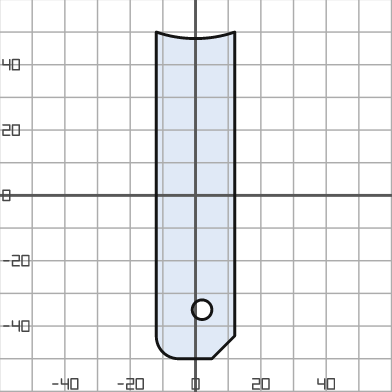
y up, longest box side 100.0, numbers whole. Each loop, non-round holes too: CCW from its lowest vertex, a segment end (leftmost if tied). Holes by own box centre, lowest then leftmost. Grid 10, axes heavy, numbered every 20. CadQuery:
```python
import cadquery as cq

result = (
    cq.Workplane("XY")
    .moveTo(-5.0, -50.0)
    .lineTo(5.0, -50.0)
    .lineTo(12.0, -43.0)
    .lineTo(12.0, 50.0)
    .threePointArc((0.0, 48.0), (-12.0, 50.0))
    .lineTo(-12.0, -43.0)
    .threePointArc((-10.0, -48.0), (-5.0, -50.0))
    .close()
    .moveTo(2.0, -35.0)
    .circle(3.0)
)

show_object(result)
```